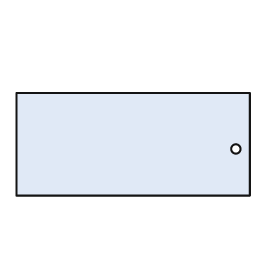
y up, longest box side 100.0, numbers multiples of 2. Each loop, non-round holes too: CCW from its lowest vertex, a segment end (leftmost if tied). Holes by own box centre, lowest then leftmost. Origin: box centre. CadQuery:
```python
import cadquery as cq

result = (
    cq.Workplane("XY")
    .moveTo(-50.0, -22.0)
    .lineTo(50.0, -22.0)
    .lineTo(50.0, 22.0)
    .lineTo(-50.0, 22.0)
    .close()
    .moveTo(44.0, -2.0)
    .circle(2.0)
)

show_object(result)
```